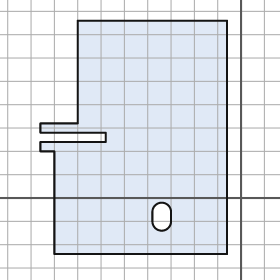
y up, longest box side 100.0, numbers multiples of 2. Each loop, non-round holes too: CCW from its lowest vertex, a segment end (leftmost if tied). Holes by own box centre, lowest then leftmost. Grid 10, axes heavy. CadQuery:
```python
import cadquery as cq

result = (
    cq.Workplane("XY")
    .moveTo(-80.0, -24.0)
    .lineTo(-6.0, -24.0)
    .lineTo(-6.0, 76.0)
    .lineTo(-70.0, 76.0)
    .lineTo(-70.0, 32.0)
    .lineTo(-86.0, 32.0)
    .lineTo(-86.0, 28.0)
    .lineTo(-58.0, 28.0)
    .lineTo(-58.0, 24.0)
    .lineTo(-86.0, 24.0)
    .lineTo(-86.0, 20.0)
    .lineTo(-80.0, 20.0)
    .close()
    .moveTo(-38.0, -10.0)
    .threePointArc((-34.0, -14.0), (-30.0, -10.0))
    .lineTo(-30.0, -6.0)
    .threePointArc((-34.0, -2.0), (-38.0, -6.0))
    .close()
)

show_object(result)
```